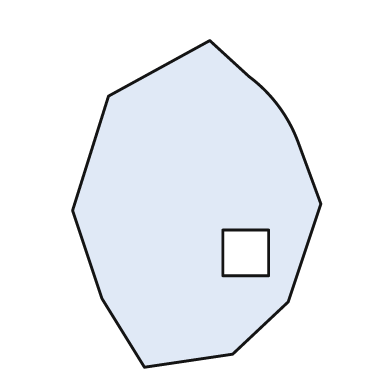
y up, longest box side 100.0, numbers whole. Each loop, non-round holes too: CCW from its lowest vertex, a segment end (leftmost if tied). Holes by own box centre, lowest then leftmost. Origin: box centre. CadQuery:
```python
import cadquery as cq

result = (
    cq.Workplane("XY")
    .moveTo(-16.0, -50.0)
    .lineTo(11.0, -46.0)
    .lineTo(28.0, -30.0)
    .lineTo(38.0, 0.0)
    .lineTo(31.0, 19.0)
    .threePointArc((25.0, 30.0), (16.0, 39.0))
    .lineTo(4.0, 50.0)
    .lineTo(-27.0, 33.0)
    .lineTo(-38.0, -2.0)
    .lineTo(-29.0, -29.0)
    .close()
    .moveTo(8.0, -22.0)
    .lineTo(22.0, -22.0)
    .lineTo(22.0, -8.0)
    .lineTo(8.0, -8.0)
    .close()
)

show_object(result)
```